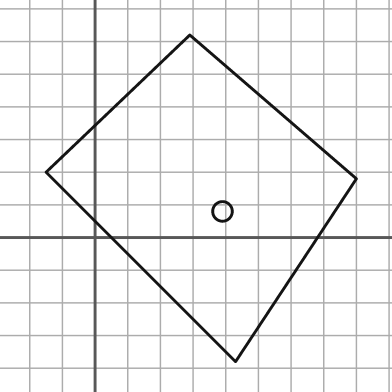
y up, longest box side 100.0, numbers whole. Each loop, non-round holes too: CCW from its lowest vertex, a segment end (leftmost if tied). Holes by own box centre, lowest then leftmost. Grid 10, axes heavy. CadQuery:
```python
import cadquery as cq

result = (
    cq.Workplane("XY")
    .moveTo(43.0, -38.0)
    .lineTo(80.0, 18.0)
    .lineTo(29.0, 62.0)
    .lineTo(-15.0, 20.0)
    .close()
    .moveTo(39.0, 8.0)
    .circle(3.0)
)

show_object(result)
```